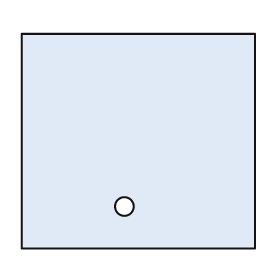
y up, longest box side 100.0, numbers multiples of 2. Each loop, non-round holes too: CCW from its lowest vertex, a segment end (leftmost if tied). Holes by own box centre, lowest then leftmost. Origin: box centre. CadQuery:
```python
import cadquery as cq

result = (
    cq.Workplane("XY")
    .moveTo(-50.0, -46.0)
    .lineTo(50.0, -46.0)
    .lineTo(50.0, 46.0)
    .lineTo(-50.0, 46.0)
    .close()
    .moveTo(-6.0, -28.0)
    .circle(4.0)
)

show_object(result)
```